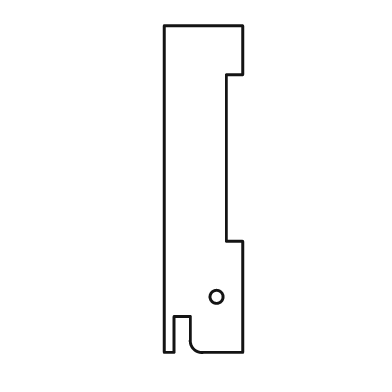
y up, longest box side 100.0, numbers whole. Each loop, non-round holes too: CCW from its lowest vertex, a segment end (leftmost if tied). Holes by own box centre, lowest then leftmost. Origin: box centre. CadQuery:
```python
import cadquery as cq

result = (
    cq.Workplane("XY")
    .moveTo(-12.0, -50.0)
    .lineTo(-9.0, -50.0)
    .lineTo(-9.0, -39.0)
    .lineTo(-4.0, -39.0)
    .lineTo(-4.0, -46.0)
    .threePointArc((-3.0, -49.0), (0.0, -50.0))
    .lineTo(12.0, -50.0)
    .lineTo(12.0, -16.0)
    .lineTo(7.0, -16.0)
    .lineTo(7.0, 35.0)
    .lineTo(12.0, 35.0)
    .lineTo(12.0, 50.0)
    .lineTo(-12.0, 50.0)
    .close()
    .moveTo(4.0, -33.0)
    .circle(2.0)
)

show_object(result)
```